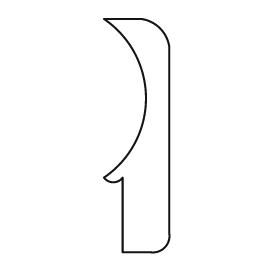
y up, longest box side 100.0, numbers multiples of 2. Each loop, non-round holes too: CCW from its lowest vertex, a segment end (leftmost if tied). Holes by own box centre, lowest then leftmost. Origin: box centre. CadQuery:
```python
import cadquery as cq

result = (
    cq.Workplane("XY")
    .moveTo(-6.0, -50.0)
    .lineTo(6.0, -50.0)
    .threePointArc((12.0, -48.0), (14.0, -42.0))
    .lineTo(14.0, 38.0)
    .threePointArc((10.0, 46.0), (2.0, 50.0))
    .lineTo(-14.0, 50.0)
    .threePointArc((4.0, 16.0), (-14.0, -18.0))
    .threePointArc((-10.0, -20.0), (-6.0, -18.0))
    .close()
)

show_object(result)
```